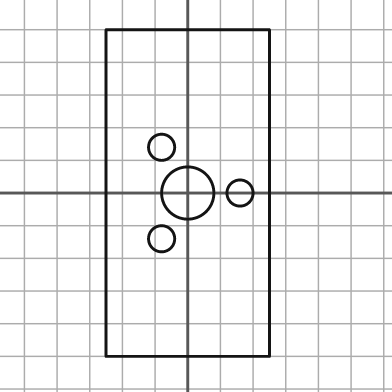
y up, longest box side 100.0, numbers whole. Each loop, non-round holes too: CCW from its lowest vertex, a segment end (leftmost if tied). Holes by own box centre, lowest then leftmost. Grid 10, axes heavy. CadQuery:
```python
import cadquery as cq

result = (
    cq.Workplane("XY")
    .moveTo(-25.0, -50.0)
    .lineTo(25.0, -50.0)
    .lineTo(25.0, 50.0)
    .lineTo(-25.0, 50.0)
    .close()
    .moveTo(-8.0, -14.0)
    .circle(4.0)
    .moveTo(0.0, 0.0)
    .circle(8.0)
    .moveTo(16.0, 0.0)
    .circle(4.0)
    .moveTo(-8.0, 14.0)
    .circle(4.0)
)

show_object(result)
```